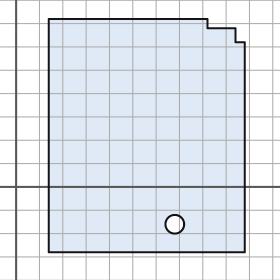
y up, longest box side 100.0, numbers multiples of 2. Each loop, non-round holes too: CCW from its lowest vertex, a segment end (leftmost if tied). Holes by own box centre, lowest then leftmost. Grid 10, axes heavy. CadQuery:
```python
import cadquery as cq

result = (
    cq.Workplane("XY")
    .moveTo(14.0, -28.0)
    .lineTo(98.0, -28.0)
    .lineTo(98.0, 62.0)
    .lineTo(94.0, 62.0)
    .lineTo(94.0, 68.0)
    .lineTo(82.0, 68.0)
    .lineTo(82.0, 72.0)
    .lineTo(14.0, 72.0)
    .close()
    .moveTo(68.0, -16.0)
    .circle(4.0)
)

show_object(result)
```